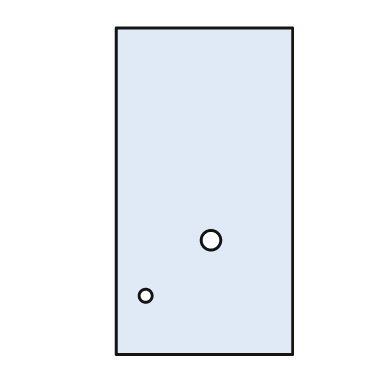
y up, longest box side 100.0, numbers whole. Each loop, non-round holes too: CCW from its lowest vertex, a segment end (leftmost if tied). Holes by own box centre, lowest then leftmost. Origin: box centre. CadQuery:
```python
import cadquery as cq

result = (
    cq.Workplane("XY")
    .moveTo(-27.0, -50.0)
    .lineTo(27.0, -50.0)
    .lineTo(27.0, 50.0)
    .lineTo(-27.0, 50.0)
    .close()
    .moveTo(-18.0, -32.0)
    .circle(2.0)
    .moveTo(2.0, -15.0)
    .circle(3.0)
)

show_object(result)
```